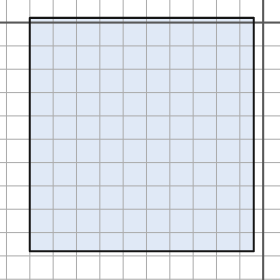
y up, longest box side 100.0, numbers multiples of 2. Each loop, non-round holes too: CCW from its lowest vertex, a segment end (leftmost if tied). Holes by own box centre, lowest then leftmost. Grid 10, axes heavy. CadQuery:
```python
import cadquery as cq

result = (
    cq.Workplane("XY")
    .moveTo(-100.0, -98.0)
    .lineTo(-4.0, -98.0)
    .lineTo(-4.0, 2.0)
    .lineTo(-100.0, 2.0)
    .close()
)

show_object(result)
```